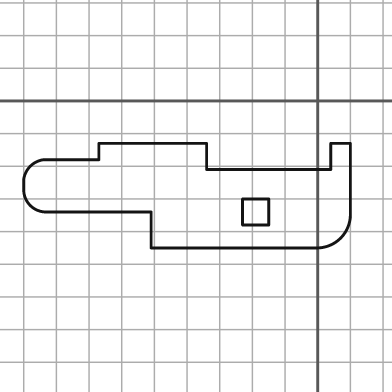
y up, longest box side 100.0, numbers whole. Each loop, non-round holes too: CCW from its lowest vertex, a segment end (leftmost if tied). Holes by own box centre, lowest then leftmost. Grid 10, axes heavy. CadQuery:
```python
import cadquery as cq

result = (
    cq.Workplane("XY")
    .moveTo(-51.0, -45.0)
    .lineTo(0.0, -45.0)
    .threePointArc((7.0, -42.0), (10.0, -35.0))
    .lineTo(10.0, -13.0)
    .lineTo(4.0, -13.0)
    .lineTo(4.0, -21.0)
    .lineTo(-34.0, -21.0)
    .lineTo(-34.0, -13.0)
    .lineTo(-67.0, -13.0)
    .lineTo(-67.0, -18.0)
    .lineTo(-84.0, -18.0)
    .threePointArc((-88.0, -20.0), (-90.0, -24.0))
    .lineTo(-90.0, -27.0)
    .threePointArc((-88.0, -32.0), (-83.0, -34.0))
    .lineTo(-51.0, -34.0)
    .close()
    .moveTo(-23.0, -38.0)
    .lineTo(-15.0, -38.0)
    .lineTo(-15.0, -30.0)
    .lineTo(-23.0, -30.0)
    .close()
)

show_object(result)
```